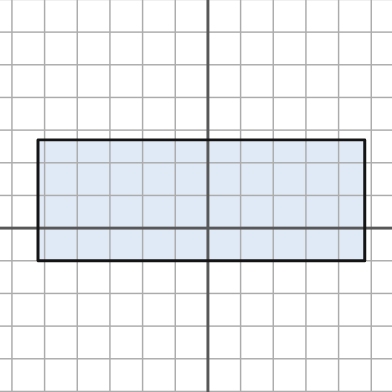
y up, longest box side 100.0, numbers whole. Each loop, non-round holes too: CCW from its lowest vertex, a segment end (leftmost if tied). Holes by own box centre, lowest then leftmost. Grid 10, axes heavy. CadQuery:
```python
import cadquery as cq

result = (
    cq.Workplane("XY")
    .moveTo(-52.0, -10.0)
    .lineTo(48.0, -10.0)
    .lineTo(48.0, 27.0)
    .lineTo(-52.0, 27.0)
    .close()
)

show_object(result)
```